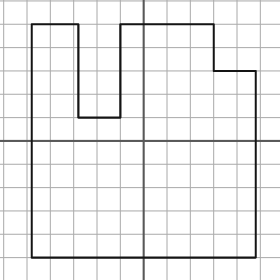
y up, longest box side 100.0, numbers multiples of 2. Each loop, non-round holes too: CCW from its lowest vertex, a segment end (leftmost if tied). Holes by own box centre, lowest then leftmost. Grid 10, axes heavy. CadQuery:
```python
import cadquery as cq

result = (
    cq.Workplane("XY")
    .moveTo(-48.0, -50.0)
    .lineTo(48.0, -50.0)
    .lineTo(48.0, 30.0)
    .lineTo(30.0, 30.0)
    .lineTo(30.0, 50.0)
    .lineTo(-10.0, 50.0)
    .lineTo(-10.0, 10.0)
    .lineTo(-28.0, 10.0)
    .lineTo(-28.0, 50.0)
    .lineTo(-48.0, 50.0)
    .close()
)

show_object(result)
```